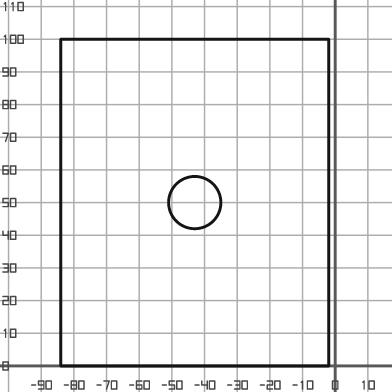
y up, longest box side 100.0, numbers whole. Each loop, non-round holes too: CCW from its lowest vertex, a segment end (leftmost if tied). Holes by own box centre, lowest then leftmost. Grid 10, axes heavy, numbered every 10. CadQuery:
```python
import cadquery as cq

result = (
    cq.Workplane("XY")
    .moveTo(-84.0, 0.0)
    .lineTo(-2.0, 0.0)
    .lineTo(-2.0, 100.0)
    .lineTo(-84.0, 100.0)
    .close()
    .moveTo(-43.0, 50.0)
    .circle(8.0)
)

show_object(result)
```